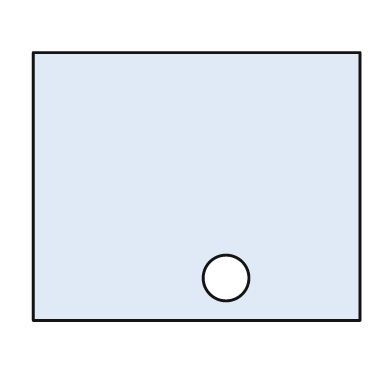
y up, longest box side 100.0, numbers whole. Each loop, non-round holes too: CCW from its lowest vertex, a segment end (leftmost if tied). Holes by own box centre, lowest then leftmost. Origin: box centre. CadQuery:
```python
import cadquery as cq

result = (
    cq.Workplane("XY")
    .moveTo(-50.0, -41.0)
    .lineTo(50.0, -41.0)
    .lineTo(50.0, 41.0)
    .lineTo(-50.0, 41.0)
    .close()
    .moveTo(9.0, -28.0)
    .circle(7.0)
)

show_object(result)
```